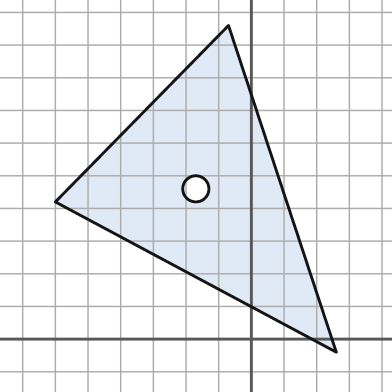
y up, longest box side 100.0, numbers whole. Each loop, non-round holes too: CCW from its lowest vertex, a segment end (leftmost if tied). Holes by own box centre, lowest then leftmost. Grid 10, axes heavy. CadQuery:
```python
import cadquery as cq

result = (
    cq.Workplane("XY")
    .moveTo(26.0, -4.0)
    .lineTo(-7.0, 96.0)
    .lineTo(-60.0, 42.0)
    .close()
    .moveTo(-17.0, 46.0)
    .circle(4.0)
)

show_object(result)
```